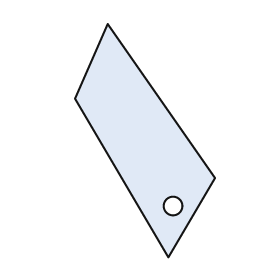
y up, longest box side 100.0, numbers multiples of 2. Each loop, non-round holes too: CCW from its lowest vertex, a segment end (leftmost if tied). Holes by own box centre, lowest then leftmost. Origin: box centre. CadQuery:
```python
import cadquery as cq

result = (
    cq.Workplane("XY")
    .moveTo(10.0, -50.0)
    .lineTo(30.0, -16.0)
    .lineTo(-16.0, 50.0)
    .lineTo(-30.0, 18.0)
    .close()
    .moveTo(12.0, -28.0)
    .circle(4.0)
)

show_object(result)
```